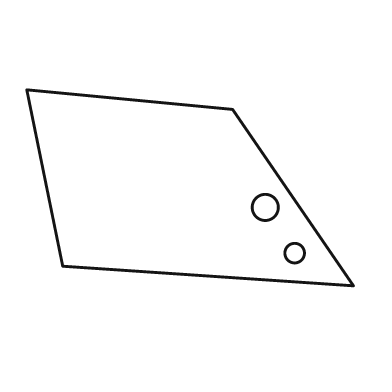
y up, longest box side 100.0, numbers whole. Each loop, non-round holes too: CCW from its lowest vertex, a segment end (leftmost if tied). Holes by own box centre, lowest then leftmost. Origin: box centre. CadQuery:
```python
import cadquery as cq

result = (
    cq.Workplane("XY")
    .moveTo(50.0, -30.0)
    .lineTo(13.0, 24.0)
    .lineTo(-50.0, 30.0)
    .lineTo(-39.0, -24.0)
    .close()
    .moveTo(32.0, -20.0)
    .circle(3.0)
    .moveTo(23.0, -6.0)
    .circle(4.0)
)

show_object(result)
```